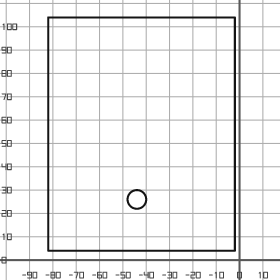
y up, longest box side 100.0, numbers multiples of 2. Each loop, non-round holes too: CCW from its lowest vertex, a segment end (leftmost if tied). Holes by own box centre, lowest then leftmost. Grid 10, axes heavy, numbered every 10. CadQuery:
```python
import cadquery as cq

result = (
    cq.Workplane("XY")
    .moveTo(-82.0, 4.0)
    .lineTo(-2.0, 4.0)
    .lineTo(-2.0, 104.0)
    .lineTo(-82.0, 104.0)
    .close()
    .moveTo(-44.0, 26.0)
    .circle(4.0)
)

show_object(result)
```